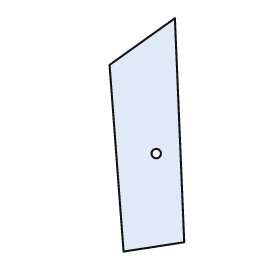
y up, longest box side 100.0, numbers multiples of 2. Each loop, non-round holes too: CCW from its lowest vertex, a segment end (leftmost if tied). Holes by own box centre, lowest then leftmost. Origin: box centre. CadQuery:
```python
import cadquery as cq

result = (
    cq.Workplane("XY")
    .moveTo(-10.0, -50.0)
    .lineTo(16.0, -46.0)
    .lineTo(12.0, 50.0)
    .lineTo(-16.0, 30.0)
    .close()
    .moveTo(4.0, -8.0)
    .circle(2.0)
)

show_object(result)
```